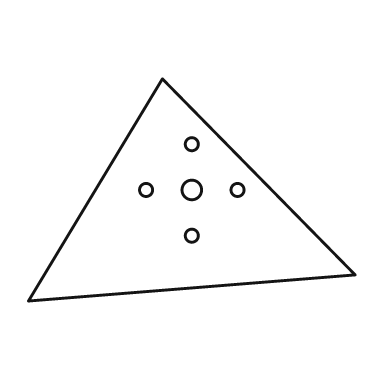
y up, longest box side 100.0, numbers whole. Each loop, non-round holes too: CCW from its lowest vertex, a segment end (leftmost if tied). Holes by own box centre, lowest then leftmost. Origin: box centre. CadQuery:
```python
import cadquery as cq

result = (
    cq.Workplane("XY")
    .moveTo(-50.0, -34.0)
    .lineTo(50.0, -26.0)
    .lineTo(-9.0, 34.0)
    .close()
    .moveTo(0.0, -14.0)
    .circle(2.0)
    .moveTo(-14.0, 0.0)
    .circle(2.0)
    .moveTo(0.0, 0.0)
    .circle(3.0)
    .moveTo(14.0, 0.0)
    .circle(2.0)
    .moveTo(0.0, 14.0)
    .circle(2.0)
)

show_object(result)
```